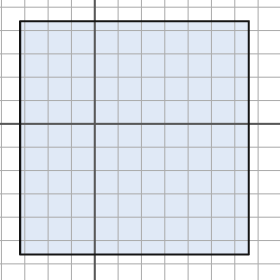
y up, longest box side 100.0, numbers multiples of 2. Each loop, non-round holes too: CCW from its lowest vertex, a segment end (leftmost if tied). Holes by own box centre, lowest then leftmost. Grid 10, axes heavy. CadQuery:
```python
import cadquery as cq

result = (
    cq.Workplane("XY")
    .moveTo(-32.0, -56.0)
    .lineTo(66.0, -56.0)
    .lineTo(66.0, 44.0)
    .lineTo(-32.0, 44.0)
    .close()
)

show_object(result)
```